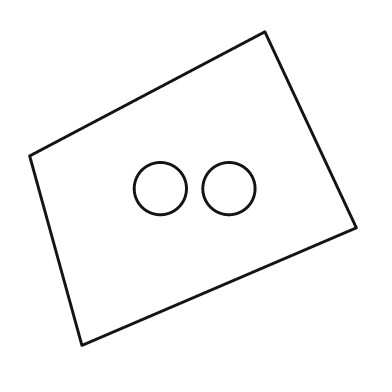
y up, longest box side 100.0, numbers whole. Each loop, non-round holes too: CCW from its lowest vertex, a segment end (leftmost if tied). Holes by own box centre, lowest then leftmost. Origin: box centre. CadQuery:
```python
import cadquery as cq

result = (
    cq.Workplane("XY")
    .moveTo(-34.0, -48.0)
    .lineTo(50.0, -12.0)
    .lineTo(22.0, 48.0)
    .lineTo(-50.0, 10.0)
    .close()
    .moveTo(-10.0, 0.0)
    .circle(8.0)
    .moveTo(11.0, 0.0)
    .circle(8.0)
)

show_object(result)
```